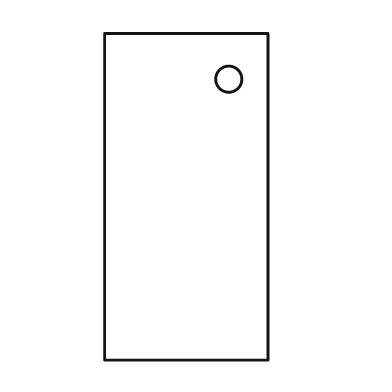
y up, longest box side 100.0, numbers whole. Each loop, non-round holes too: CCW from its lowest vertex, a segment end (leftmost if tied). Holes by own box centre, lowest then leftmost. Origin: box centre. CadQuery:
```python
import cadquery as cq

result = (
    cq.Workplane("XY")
    .moveTo(-25.0, -50.0)
    .lineTo(25.0, -50.0)
    .lineTo(25.0, 50.0)
    .lineTo(-25.0, 50.0)
    .close()
    .moveTo(13.0, 36.0)
    .circle(4.0)
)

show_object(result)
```